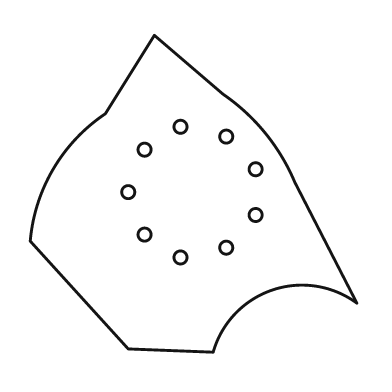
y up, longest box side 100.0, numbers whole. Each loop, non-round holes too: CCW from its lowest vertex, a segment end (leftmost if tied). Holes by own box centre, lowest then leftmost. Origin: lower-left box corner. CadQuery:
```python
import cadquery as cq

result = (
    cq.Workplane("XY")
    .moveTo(56.0, 0.0)
    .threePointArc((74.0, 19.0), (100.0, 15.0))
    .lineTo(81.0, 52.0)
    .threePointArc((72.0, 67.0), (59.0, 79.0))
    .lineTo(38.0, 97.0)
    .lineTo(23.0, 73.0)
    .threePointArc((7.0, 56.0), (0.0, 34.0))
    .lineTo(30.0, 1.0)
    .close()
    .moveTo(46.0, 29.0)
    .circle(2.0)
    .moveTo(60.0, 32.0)
    .circle(2.0)
    .moveTo(35.0, 36.0)
    .circle(2.0)
    .moveTo(69.0, 42.0)
    .circle(2.0)
    .moveTo(30.0, 49.0)
    .circle(2.0)
    .moveTo(69.0, 56.0)
    .circle(2.0)
    .moveTo(35.0, 62.0)
    .circle(2.0)
    .moveTo(60.0, 66.0)
    .circle(2.0)
    .moveTo(46.0, 69.0)
    .circle(2.0)
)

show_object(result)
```